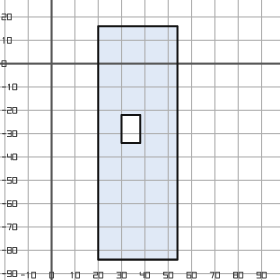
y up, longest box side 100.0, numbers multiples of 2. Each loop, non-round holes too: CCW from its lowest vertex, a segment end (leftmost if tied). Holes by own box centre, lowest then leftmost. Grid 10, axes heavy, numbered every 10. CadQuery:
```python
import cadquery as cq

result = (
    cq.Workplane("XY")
    .moveTo(20.0, -84.0)
    .lineTo(54.0, -84.0)
    .lineTo(54.0, 16.0)
    .lineTo(20.0, 16.0)
    .close()
    .moveTo(30.0, -34.0)
    .lineTo(38.0, -34.0)
    .lineTo(38.0, -22.0)
    .lineTo(30.0, -22.0)
    .close()
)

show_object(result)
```